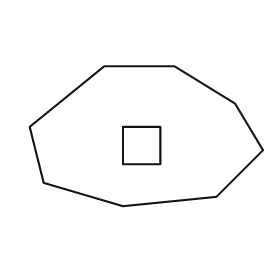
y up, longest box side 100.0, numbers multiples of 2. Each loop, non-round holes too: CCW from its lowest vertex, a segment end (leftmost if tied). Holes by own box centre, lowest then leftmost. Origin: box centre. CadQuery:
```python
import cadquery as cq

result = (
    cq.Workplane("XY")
    .moveTo(-10.0, -30.0)
    .lineTo(30.0, -26.0)
    .lineTo(50.0, -6.0)
    .lineTo(38.0, 14.0)
    .lineTo(12.0, 30.0)
    .lineTo(-18.0, 30.0)
    .lineTo(-50.0, 4.0)
    .lineTo(-44.0, -20.0)
    .close()
    .moveTo(-10.0, -12.0)
    .lineTo(6.0, -12.0)
    .lineTo(6.0, 4.0)
    .lineTo(-10.0, 4.0)
    .close()
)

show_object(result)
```